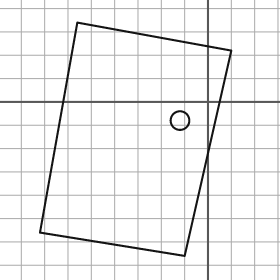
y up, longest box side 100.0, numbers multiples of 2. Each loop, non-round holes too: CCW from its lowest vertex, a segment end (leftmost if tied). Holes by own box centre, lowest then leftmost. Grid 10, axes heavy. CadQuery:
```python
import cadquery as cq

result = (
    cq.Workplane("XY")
    .moveTo(-10.0, -66.0)
    .lineTo(10.0, 22.0)
    .lineTo(-56.0, 34.0)
    .lineTo(-72.0, -56.0)
    .close()
    .moveTo(-12.0, -8.0)
    .circle(4.0)
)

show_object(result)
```